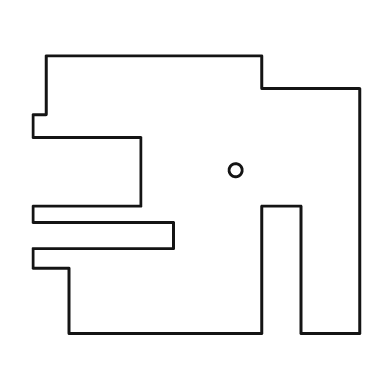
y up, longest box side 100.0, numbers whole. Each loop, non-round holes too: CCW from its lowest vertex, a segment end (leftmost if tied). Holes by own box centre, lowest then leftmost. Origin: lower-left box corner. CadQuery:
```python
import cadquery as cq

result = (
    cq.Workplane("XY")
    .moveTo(11.0, 0.0)
    .lineTo(70.0, 0.0)
    .lineTo(70.0, 39.0)
    .lineTo(82.0, 39.0)
    .lineTo(82.0, 0.0)
    .lineTo(100.0, 0.0)
    .lineTo(100.0, 75.0)
    .lineTo(70.0, 75.0)
    .lineTo(70.0, 85.0)
    .lineTo(4.0, 85.0)
    .lineTo(4.0, 67.0)
    .lineTo(0.0, 67.0)
    .lineTo(0.0, 60.0)
    .lineTo(33.0, 60.0)
    .lineTo(33.0, 39.0)
    .lineTo(0.0, 39.0)
    .lineTo(0.0, 34.0)
    .lineTo(43.0, 34.0)
    .lineTo(43.0, 26.0)
    .lineTo(0.0, 26.0)
    .lineTo(0.0, 20.0)
    .lineTo(11.0, 20.0)
    .close()
    .moveTo(62.0, 50.0)
    .circle(2.0)
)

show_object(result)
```